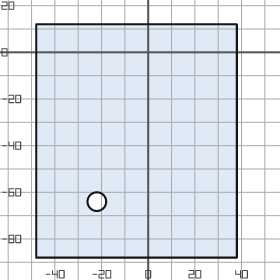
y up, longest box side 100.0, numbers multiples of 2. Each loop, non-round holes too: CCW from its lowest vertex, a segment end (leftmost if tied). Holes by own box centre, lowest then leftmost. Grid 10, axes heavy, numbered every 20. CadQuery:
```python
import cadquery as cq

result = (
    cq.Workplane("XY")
    .moveTo(-48.0, -88.0)
    .lineTo(38.0, -88.0)
    .lineTo(38.0, 12.0)
    .lineTo(-48.0, 12.0)
    .close()
    .moveTo(-22.0, -64.0)
    .circle(4.0)
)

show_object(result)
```